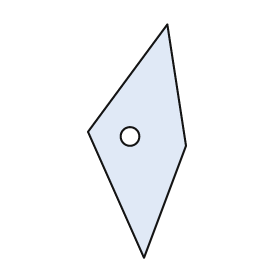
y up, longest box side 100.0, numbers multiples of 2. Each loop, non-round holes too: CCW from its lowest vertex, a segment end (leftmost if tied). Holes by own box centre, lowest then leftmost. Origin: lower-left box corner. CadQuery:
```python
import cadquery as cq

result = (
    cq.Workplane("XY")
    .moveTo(24.0, 0.0)
    .lineTo(42.0, 48.0)
    .lineTo(34.0, 100.0)
    .lineTo(0.0, 54.0)
    .close()
    .moveTo(18.0, 52.0)
    .circle(4.0)
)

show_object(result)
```